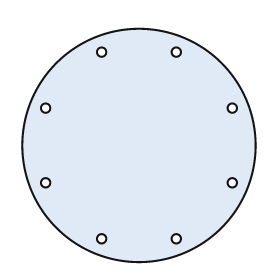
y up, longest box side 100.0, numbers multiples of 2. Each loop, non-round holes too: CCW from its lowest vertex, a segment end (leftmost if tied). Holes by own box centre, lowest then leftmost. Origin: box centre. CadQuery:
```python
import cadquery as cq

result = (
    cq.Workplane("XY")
    .moveTo(0.0, 0.0)
    .circle(50.0)
    .moveTo(-16.0, -40.0)
    .circle(2.0)
    .moveTo(16.0, -40.0)
    .circle(2.0)
    .moveTo(-40.0, -16.0)
    .circle(2.0)
    .moveTo(40.0, -16.0)
    .circle(2.0)
    .moveTo(-40.0, 16.0)
    .circle(2.0)
    .moveTo(40.0, 16.0)
    .circle(2.0)
    .moveTo(-16.0, 40.0)
    .circle(2.0)
    .moveTo(16.0, 40.0)
    .circle(2.0)
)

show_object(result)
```